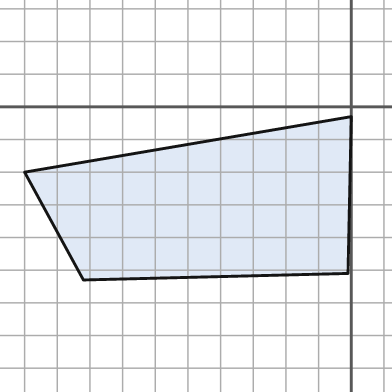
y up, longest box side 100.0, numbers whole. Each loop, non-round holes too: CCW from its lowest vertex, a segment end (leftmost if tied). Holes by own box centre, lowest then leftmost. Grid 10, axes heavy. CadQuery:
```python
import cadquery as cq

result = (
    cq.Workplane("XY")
    .moveTo(-82.0, -53.0)
    .lineTo(-1.0, -51.0)
    .lineTo(0.0, -3.0)
    .lineTo(-100.0, -20.0)
    .close()
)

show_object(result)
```